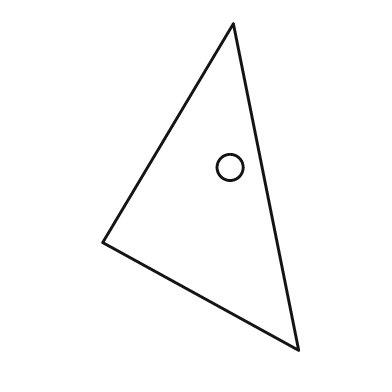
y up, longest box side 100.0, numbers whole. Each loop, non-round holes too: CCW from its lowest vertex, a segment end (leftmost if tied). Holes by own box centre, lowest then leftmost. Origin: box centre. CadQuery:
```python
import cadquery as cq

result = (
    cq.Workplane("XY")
    .moveTo(30.0, -50.0)
    .lineTo(10.0, 50.0)
    .lineTo(-30.0, -17.0)
    .close()
    .moveTo(9.0, 6.0)
    .circle(4.0)
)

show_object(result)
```